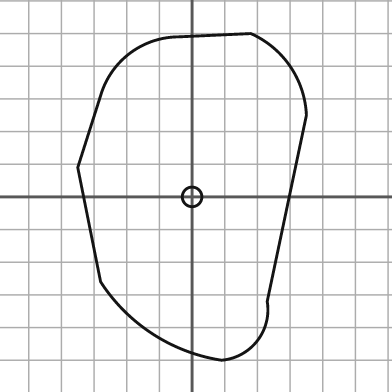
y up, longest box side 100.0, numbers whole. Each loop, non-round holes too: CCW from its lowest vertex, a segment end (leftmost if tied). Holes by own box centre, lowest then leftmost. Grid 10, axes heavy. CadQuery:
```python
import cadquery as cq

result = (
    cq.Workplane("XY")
    .moveTo(9.0, -50.0)
    .threePointArc((20.0, -44.0), (23.0, -32.0))
    .lineTo(35.0, 25.0)
    .threePointArc((30.0, 40.0), (18.0, 50.0))
    .lineTo(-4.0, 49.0)
    .threePointArc((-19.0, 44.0), (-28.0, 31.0))
    .lineTo(-35.0, 9.0)
    .lineTo(-28.0, -26.0)
    .threePointArc((-12.0, -42.0), (9.0, -50.0))
    .close()
    .moveTo(0.0, 0.0)
    .circle(3.0)
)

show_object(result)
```